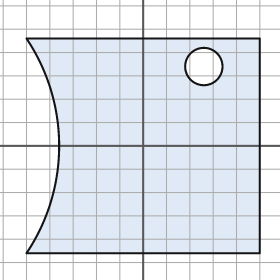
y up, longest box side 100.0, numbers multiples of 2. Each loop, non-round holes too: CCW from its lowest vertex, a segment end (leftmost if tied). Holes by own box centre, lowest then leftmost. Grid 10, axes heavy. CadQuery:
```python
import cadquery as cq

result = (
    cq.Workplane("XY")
    .moveTo(-50.0, -46.0)
    .lineTo(50.0, -46.0)
    .lineTo(50.0, 46.0)
    .lineTo(-50.0, 46.0)
    .threePointArc((-36.0, 0.0), (-50.0, -46.0))
    .close()
    .moveTo(26.0, 34.0)
    .circle(8.0)
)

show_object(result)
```